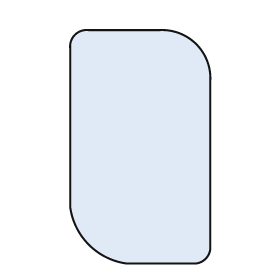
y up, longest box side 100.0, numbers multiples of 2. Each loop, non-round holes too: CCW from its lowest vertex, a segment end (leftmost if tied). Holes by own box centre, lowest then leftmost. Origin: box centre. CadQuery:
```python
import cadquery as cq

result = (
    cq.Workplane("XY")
    .moveTo(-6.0, -50.0)
    .lineTo(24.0, -50.0)
    .threePointArc((28.0, -48.0), (30.0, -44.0))
    .lineTo(30.0, 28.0)
    .threePointArc((24.0, 44.0), (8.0, 50.0))
    .lineTo(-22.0, 50.0)
    .threePointArc((-28.0, 48.0), (-30.0, 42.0))
    .lineTo(-30.0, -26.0)
    .threePointArc((-22.0, -42.0), (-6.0, -50.0))
    .close()
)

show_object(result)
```